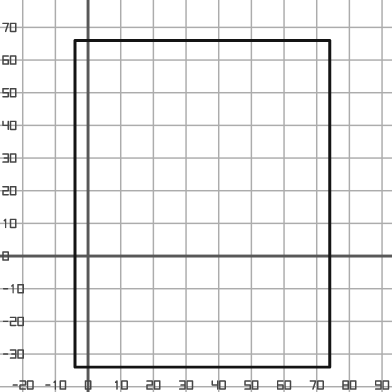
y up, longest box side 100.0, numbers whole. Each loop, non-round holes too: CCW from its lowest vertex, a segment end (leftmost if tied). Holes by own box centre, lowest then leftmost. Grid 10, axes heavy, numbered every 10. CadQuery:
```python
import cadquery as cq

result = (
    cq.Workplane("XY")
    .moveTo(-4.0, -34.0)
    .lineTo(74.0, -34.0)
    .lineTo(74.0, 66.0)
    .lineTo(-4.0, 66.0)
    .close()
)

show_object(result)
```